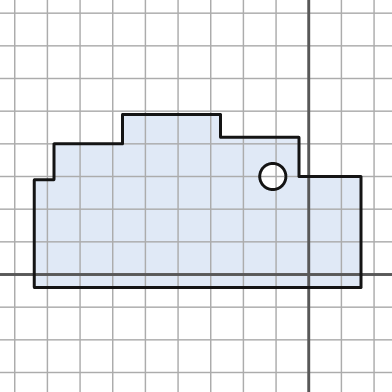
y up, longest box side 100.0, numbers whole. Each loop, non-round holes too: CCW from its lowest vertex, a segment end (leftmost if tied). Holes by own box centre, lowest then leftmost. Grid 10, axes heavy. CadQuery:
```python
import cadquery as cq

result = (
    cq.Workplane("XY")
    .moveTo(-84.0, -4.0)
    .lineTo(16.0, -4.0)
    .lineTo(16.0, 30.0)
    .lineTo(-3.0, 30.0)
    .lineTo(-3.0, 42.0)
    .lineTo(-27.0, 42.0)
    .lineTo(-27.0, 49.0)
    .lineTo(-57.0, 49.0)
    .lineTo(-57.0, 40.0)
    .lineTo(-78.0, 40.0)
    .lineTo(-78.0, 29.0)
    .lineTo(-84.0, 29.0)
    .close()
    .moveTo(-11.0, 30.0)
    .circle(4.0)
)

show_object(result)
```